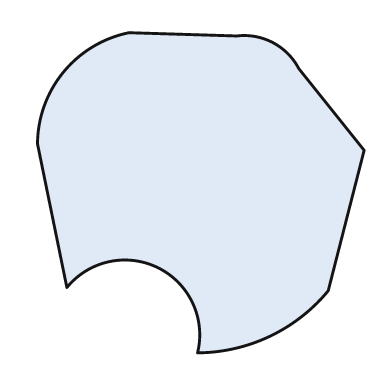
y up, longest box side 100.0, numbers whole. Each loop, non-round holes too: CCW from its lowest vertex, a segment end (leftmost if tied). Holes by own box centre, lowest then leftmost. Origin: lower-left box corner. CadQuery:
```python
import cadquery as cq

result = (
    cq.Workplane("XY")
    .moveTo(49.0, 0.0)
    .threePointArc((71.0, 5.0), (89.0, 19.0))
    .lineTo(100.0, 62.0)
    .lineTo(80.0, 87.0)
    .threePointArc((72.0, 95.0), (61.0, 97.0))
    .lineTo(28.0, 98.0)
    .threePointArc((8.0, 86.0), (0.0, 64.0))
    .lineTo(9.0, 20.0)
    .threePointArc((37.0, 26.0), (49.0, 0.0))
    .close()
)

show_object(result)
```